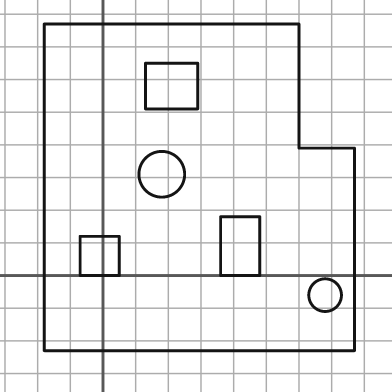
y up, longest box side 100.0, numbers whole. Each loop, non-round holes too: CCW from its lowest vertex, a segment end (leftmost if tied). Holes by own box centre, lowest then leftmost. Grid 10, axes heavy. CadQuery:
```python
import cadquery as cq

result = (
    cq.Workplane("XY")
    .moveTo(-18.0, -23.0)
    .lineTo(77.0, -23.0)
    .lineTo(77.0, 39.0)
    .lineTo(60.0, 39.0)
    .lineTo(60.0, 77.0)
    .lineTo(-18.0, 77.0)
    .close()
    .moveTo(68.0, -6.0)
    .circle(5.0)
    .moveTo(-7.0, 0.0)
    .lineTo(5.0, 0.0)
    .lineTo(5.0, 12.0)
    .lineTo(-7.0, 12.0)
    .close()
    .moveTo(36.0, 0.0)
    .lineTo(48.0, 0.0)
    .lineTo(48.0, 18.0)
    .lineTo(36.0, 18.0)
    .close()
    .moveTo(18.0, 31.0)
    .circle(7.0)
    .moveTo(13.0, 51.0)
    .lineTo(29.0, 51.0)
    .lineTo(29.0, 65.0)
    .lineTo(13.0, 65.0)
    .close()
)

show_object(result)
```